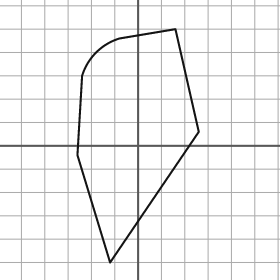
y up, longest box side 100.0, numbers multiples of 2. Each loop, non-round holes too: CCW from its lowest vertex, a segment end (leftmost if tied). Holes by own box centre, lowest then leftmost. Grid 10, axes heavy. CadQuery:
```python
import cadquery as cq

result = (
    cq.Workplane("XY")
    .moveTo(-12.0, -50.0)
    .lineTo(26.0, 6.0)
    .lineTo(16.0, 50.0)
    .lineTo(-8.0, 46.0)
    .threePointArc((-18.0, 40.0), (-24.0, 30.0))
    .lineTo(-26.0, -4.0)
    .close()
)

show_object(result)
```